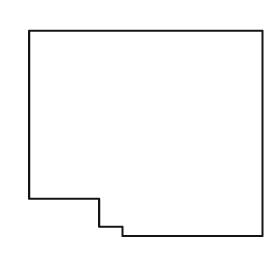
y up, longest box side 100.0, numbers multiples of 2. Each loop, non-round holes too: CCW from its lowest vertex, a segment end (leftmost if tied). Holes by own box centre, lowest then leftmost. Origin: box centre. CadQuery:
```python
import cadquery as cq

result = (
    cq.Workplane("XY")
    .moveTo(-10.0, -44.0)
    .lineTo(50.0, -44.0)
    .lineTo(50.0, 44.0)
    .lineTo(-50.0, 44.0)
    .lineTo(-50.0, -28.0)
    .lineTo(-20.0, -28.0)
    .lineTo(-20.0, -40.0)
    .lineTo(-10.0, -40.0)
    .close()
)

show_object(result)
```